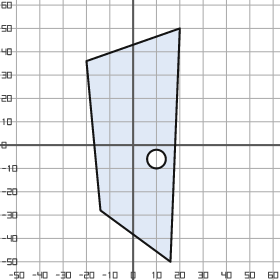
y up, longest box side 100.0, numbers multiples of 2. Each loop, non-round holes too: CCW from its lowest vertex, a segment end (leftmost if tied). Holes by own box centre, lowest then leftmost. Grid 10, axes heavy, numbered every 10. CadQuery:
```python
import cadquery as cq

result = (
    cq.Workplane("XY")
    .moveTo(16.0, -50.0)
    .lineTo(20.0, 50.0)
    .lineTo(-20.0, 36.0)
    .lineTo(-14.0, -28.0)
    .close()
    .moveTo(10.0, -6.0)
    .circle(4.0)
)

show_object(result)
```